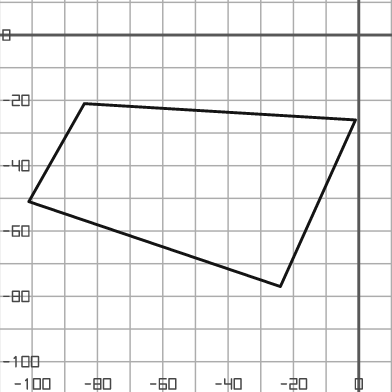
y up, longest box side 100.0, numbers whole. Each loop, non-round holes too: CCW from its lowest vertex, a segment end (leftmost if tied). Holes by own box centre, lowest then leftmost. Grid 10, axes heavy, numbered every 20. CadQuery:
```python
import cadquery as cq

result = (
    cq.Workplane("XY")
    .moveTo(-24.0, -77.0)
    .lineTo(-1.0, -26.0)
    .lineTo(-84.0, -21.0)
    .lineTo(-101.0, -51.0)
    .close()
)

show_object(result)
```